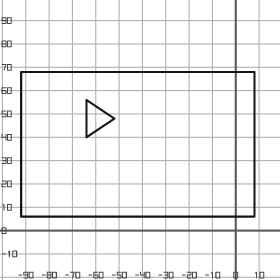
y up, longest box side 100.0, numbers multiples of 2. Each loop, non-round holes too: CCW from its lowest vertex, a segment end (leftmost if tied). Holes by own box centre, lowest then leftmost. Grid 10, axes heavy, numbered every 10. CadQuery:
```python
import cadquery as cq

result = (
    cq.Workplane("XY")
    .moveTo(-92.0, 6.0)
    .lineTo(8.0, 6.0)
    .lineTo(8.0, 68.0)
    .lineTo(-92.0, 68.0)
    .close()
    .moveTo(-64.0, 40.0)
    .lineTo(-52.0, 48.0)
    .lineTo(-64.0, 56.0)
    .close()
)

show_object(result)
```